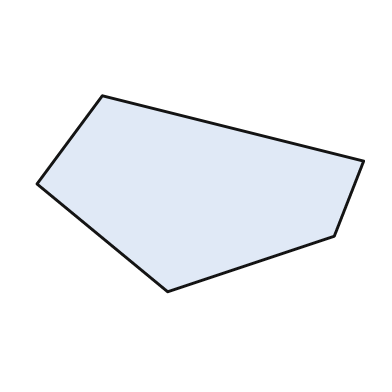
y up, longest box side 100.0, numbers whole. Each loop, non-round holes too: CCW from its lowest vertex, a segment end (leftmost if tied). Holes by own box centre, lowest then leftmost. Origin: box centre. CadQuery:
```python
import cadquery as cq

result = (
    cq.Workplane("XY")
    .moveTo(-10.0, -30.0)
    .lineTo(41.0, -13.0)
    .lineTo(50.0, 10.0)
    .lineTo(-30.0, 30.0)
    .lineTo(-50.0, 3.0)
    .close()
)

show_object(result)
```